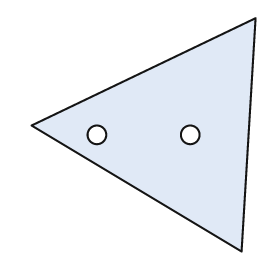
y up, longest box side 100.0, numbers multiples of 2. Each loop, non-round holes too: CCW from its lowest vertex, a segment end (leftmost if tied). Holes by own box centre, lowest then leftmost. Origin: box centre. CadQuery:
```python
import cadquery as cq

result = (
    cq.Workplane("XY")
    .moveTo(42.0, -50.0)
    .lineTo(48.0, 50.0)
    .lineTo(-48.0, 4.0)
    .close()
    .moveTo(-20.0, 0.0)
    .circle(4.0)
    .moveTo(20.0, 0.0)
    .circle(4.0)
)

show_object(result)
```